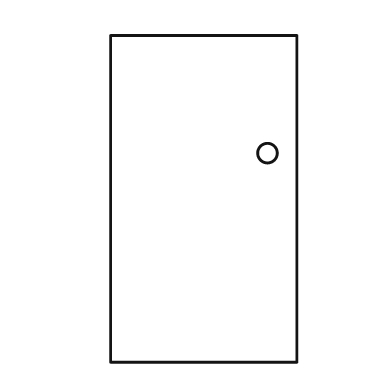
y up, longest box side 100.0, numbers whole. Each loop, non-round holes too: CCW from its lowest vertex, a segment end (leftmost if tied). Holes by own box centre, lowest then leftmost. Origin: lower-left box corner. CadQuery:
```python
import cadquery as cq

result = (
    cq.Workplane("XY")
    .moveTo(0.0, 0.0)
    .lineTo(57.0, 0.0)
    .lineTo(57.0, 100.0)
    .lineTo(0.0, 100.0)
    .close()
    .moveTo(48.0, 64.0)
    .circle(3.0)
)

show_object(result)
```